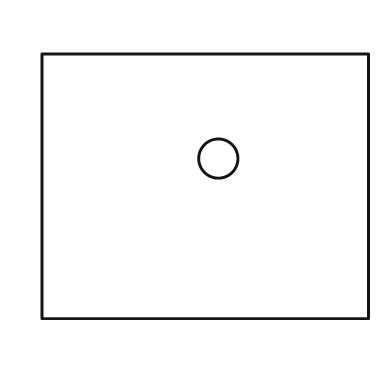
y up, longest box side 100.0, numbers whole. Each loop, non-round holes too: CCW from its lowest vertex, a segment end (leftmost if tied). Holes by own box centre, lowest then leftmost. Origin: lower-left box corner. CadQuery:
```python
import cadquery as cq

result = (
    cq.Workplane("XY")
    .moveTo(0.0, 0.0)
    .lineTo(100.0, 0.0)
    .lineTo(100.0, 81.0)
    .lineTo(0.0, 81.0)
    .close()
    .moveTo(54.0, 49.0)
    .circle(6.0)
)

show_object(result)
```